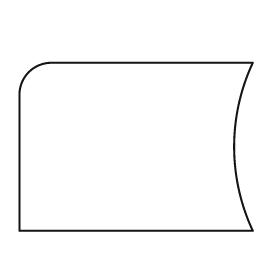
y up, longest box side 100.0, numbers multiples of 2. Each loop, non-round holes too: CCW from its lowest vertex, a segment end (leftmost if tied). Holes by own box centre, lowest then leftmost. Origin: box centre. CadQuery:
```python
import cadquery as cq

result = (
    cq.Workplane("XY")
    .moveTo(-50.0, -36.0)
    .lineTo(50.0, -36.0)
    .threePointArc((42.0, 0.0), (50.0, 36.0))
    .lineTo(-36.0, 36.0)
    .threePointArc((-46.0, 32.0), (-50.0, 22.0))
    .close()
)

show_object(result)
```